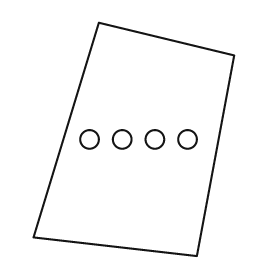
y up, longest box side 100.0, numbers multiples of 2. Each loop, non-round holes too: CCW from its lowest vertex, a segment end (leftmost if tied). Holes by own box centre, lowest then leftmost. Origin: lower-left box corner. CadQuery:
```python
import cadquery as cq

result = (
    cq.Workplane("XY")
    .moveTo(70.0, 0.0)
    .lineTo(86.0, 86.0)
    .lineTo(28.0, 100.0)
    .lineTo(0.0, 8.0)
    .close()
    .moveTo(24.0, 50.0)
    .circle(4.0)
    .moveTo(38.0, 50.0)
    .circle(4.0)
    .moveTo(52.0, 50.0)
    .circle(4.0)
    .moveTo(66.0, 50.0)
    .circle(4.0)
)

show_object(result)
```